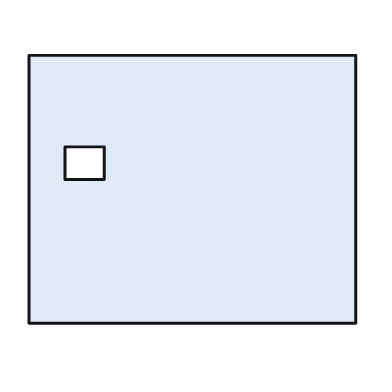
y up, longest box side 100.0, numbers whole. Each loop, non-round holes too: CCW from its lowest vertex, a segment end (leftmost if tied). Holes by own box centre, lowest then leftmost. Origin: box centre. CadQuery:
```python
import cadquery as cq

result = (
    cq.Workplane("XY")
    .moveTo(-50.0, -41.0)
    .lineTo(50.0, -41.0)
    .lineTo(50.0, 41.0)
    .lineTo(-50.0, 41.0)
    .close()
    .moveTo(-39.0, 3.0)
    .lineTo(-27.0, 3.0)
    .lineTo(-27.0, 13.0)
    .lineTo(-39.0, 13.0)
    .close()
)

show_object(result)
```